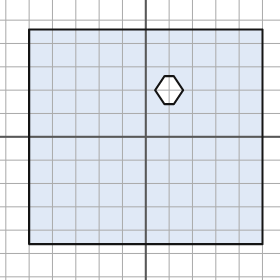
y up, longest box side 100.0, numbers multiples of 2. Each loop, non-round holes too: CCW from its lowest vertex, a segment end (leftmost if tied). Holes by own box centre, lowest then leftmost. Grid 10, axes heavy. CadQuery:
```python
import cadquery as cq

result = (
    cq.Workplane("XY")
    .moveTo(-50.0, -46.0)
    .lineTo(50.0, -46.0)
    .lineTo(50.0, 46.0)
    .lineTo(-50.0, 46.0)
    .close()
    .moveTo(8.0, 14.0)
    .lineTo(12.0, 14.0)
    .lineTo(16.0, 20.0)
    .lineTo(12.0, 26.0)
    .lineTo(8.0, 26.0)
    .lineTo(4.0, 20.0)
    .close()
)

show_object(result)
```